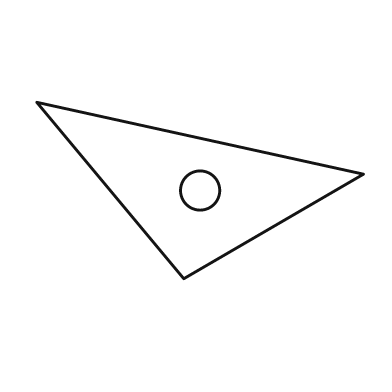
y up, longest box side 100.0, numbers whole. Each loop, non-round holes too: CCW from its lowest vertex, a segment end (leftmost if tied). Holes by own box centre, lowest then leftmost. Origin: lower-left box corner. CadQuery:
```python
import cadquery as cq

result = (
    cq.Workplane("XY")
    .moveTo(45.0, 0.0)
    .lineTo(100.0, 32.0)
    .lineTo(0.0, 54.0)
    .close()
    .moveTo(50.0, 27.0)
    .circle(6.0)
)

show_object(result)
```